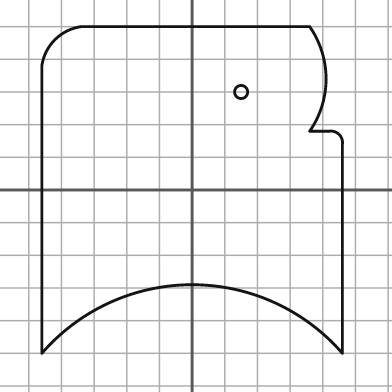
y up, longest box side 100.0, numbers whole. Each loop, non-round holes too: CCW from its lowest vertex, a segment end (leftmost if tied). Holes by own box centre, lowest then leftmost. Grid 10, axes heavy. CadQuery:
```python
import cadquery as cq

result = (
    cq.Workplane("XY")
    .moveTo(-46.0, -50.0)
    .threePointArc((0.0, -29.0), (46.0, -50.0))
    .lineTo(46.0, 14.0)
    .threePointArc((45.0, 17.0), (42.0, 18.0))
    .lineTo(36.0, 18.0)
    .threePointArc((41.0, 34.0), (36.0, 50.0))
    .lineTo(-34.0, 50.0)
    .threePointArc((-42.0, 46.0), (-46.0, 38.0))
    .close()
    .moveTo(15.0, 30.0)
    .circle(2.0)
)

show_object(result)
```